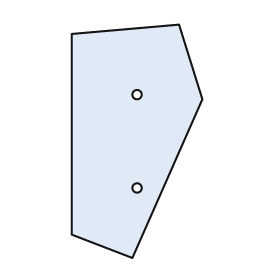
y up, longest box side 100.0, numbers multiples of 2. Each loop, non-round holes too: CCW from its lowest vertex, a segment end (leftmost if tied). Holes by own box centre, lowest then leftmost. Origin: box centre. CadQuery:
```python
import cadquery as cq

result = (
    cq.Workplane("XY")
    .moveTo(-2.0, -50.0)
    .lineTo(28.0, 18.0)
    .lineTo(18.0, 50.0)
    .lineTo(-28.0, 46.0)
    .lineTo(-28.0, -40.0)
    .close()
    .moveTo(0.0, -20.0)
    .circle(2.0)
    .moveTo(0.0, 20.0)
    .circle(2.0)
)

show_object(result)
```